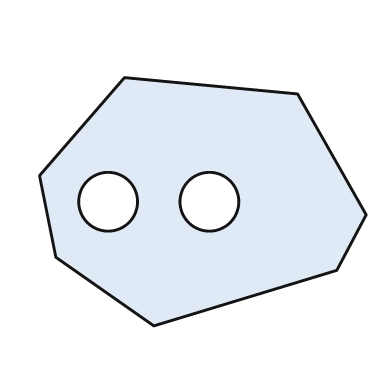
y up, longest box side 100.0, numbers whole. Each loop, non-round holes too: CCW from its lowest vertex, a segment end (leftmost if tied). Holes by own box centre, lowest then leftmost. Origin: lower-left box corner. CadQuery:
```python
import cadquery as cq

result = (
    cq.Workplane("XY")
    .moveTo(35.0, 0.0)
    .lineTo(91.0, 17.0)
    .lineTo(100.0, 34.0)
    .lineTo(79.0, 71.0)
    .lineTo(26.0, 76.0)
    .lineTo(0.0, 46.0)
    .lineTo(5.0, 21.0)
    .close()
    .moveTo(21.0, 38.0)
    .circle(9.0)
    .moveTo(52.0, 38.0)
    .circle(9.0)
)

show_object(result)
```